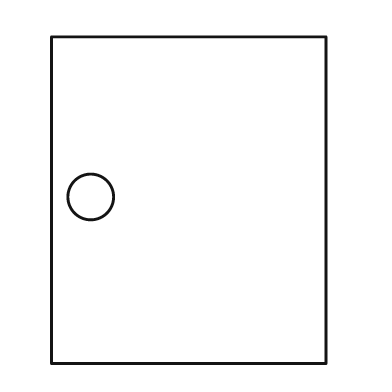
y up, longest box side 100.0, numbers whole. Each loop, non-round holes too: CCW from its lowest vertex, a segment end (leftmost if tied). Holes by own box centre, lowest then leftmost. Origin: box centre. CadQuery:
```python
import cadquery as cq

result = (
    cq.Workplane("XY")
    .moveTo(-42.0, -50.0)
    .lineTo(42.0, -50.0)
    .lineTo(42.0, 50.0)
    .lineTo(-42.0, 50.0)
    .close()
    .moveTo(-30.0, 1.0)
    .circle(7.0)
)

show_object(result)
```